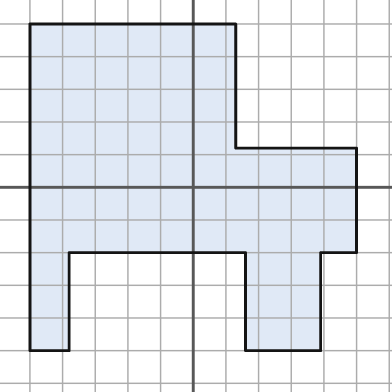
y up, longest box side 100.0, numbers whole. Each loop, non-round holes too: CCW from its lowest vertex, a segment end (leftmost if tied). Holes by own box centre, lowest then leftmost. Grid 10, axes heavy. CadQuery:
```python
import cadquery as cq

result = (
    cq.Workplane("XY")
    .moveTo(-50.0, -50.0)
    .lineTo(-38.0, -50.0)
    .lineTo(-38.0, -20.0)
    .lineTo(16.0, -20.0)
    .lineTo(16.0, -50.0)
    .lineTo(39.0, -50.0)
    .lineTo(39.0, -20.0)
    .lineTo(50.0, -20.0)
    .lineTo(50.0, 12.0)
    .lineTo(13.0, 12.0)
    .lineTo(13.0, 50.0)
    .lineTo(-50.0, 50.0)
    .close()
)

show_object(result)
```